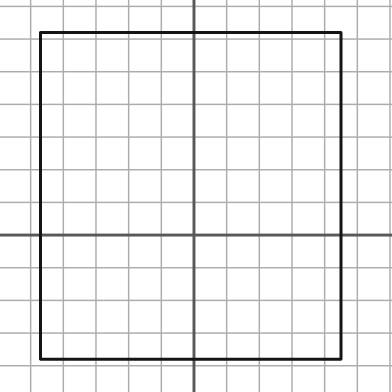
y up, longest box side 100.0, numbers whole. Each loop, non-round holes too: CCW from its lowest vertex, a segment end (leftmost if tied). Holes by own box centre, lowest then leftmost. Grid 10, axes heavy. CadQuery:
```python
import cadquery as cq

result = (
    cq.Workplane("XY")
    .moveTo(-47.0, -38.0)
    .lineTo(45.0, -38.0)
    .lineTo(45.0, 62.0)
    .lineTo(-47.0, 62.0)
    .close()
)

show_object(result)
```